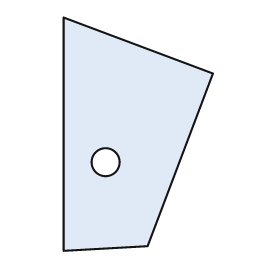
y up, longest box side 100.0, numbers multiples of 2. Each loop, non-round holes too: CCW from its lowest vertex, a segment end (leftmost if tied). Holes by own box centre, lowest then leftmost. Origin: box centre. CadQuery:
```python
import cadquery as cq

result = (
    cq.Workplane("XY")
    .moveTo(-32.0, -50.0)
    .lineTo(4.0, -48.0)
    .lineTo(32.0, 26.0)
    .lineTo(-32.0, 50.0)
    .close()
    .moveTo(-14.0, -12.0)
    .circle(6.0)
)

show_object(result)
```